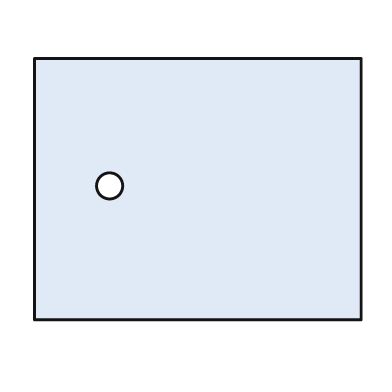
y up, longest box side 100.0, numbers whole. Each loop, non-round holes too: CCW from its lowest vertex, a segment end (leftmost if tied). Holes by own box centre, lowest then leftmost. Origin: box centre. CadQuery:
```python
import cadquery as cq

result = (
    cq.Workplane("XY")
    .moveTo(-50.0, -40.0)
    .lineTo(50.0, -40.0)
    .lineTo(50.0, 40.0)
    .lineTo(-50.0, 40.0)
    .close()
    .moveTo(-27.0, 1.0)
    .circle(4.0)
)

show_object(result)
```